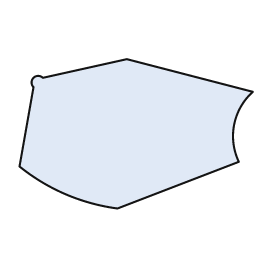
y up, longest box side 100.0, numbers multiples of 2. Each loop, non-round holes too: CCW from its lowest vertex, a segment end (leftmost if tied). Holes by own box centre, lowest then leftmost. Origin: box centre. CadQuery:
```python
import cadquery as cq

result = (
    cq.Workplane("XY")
    .moveTo(-8.0, -32.0)
    .lineTo(44.0, -12.0)
    .threePointArc((42.0, 4.0), (50.0, 18.0))
    .lineTo(-4.0, 32.0)
    .lineTo(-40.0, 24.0)
    .threePointArc((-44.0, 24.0), (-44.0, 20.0))
    .lineTo(-50.0, -14.0)
    .threePointArc((-30.0, -26.0), (-8.0, -32.0))
    .close()
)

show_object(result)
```